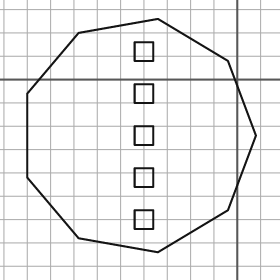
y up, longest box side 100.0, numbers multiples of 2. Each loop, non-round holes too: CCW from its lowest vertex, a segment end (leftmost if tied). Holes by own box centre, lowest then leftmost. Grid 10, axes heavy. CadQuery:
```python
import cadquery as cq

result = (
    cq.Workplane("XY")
    .moveTo(-34.0, -74.0)
    .lineTo(-4.0, -56.0)
    .lineTo(8.0, -24.0)
    .lineTo(-4.0, 8.0)
    .lineTo(-34.0, 26.0)
    .lineTo(-68.0, 20.0)
    .lineTo(-90.0, -6.0)
    .lineTo(-90.0, -42.0)
    .lineTo(-68.0, -68.0)
    .close()
    .moveTo(-44.0, -64.0)
    .lineTo(-36.0, -64.0)
    .lineTo(-36.0, -56.0)
    .lineTo(-44.0, -56.0)
    .close()
    .moveTo(-44.0, -46.0)
    .lineTo(-36.0, -46.0)
    .lineTo(-36.0, -38.0)
    .lineTo(-44.0, -38.0)
    .close()
    .moveTo(-44.0, -28.0)
    .lineTo(-36.0, -28.0)
    .lineTo(-36.0, -20.0)
    .lineTo(-44.0, -20.0)
    .close()
    .moveTo(-44.0, -10.0)
    .lineTo(-36.0, -10.0)
    .lineTo(-36.0, -2.0)
    .lineTo(-44.0, -2.0)
    .close()
    .moveTo(-44.0, 8.0)
    .lineTo(-36.0, 8.0)
    .lineTo(-36.0, 16.0)
    .lineTo(-44.0, 16.0)
    .close()
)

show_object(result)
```